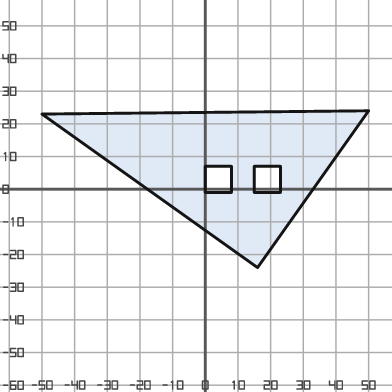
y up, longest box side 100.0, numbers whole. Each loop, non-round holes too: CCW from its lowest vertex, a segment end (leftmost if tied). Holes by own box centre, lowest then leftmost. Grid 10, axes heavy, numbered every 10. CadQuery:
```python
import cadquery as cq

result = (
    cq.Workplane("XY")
    .moveTo(16.0, -24.0)
    .lineTo(50.0, 24.0)
    .lineTo(-50.0, 23.0)
    .close()
    .moveTo(0.0, -1.0)
    .lineTo(8.0, -1.0)
    .lineTo(8.0, 7.0)
    .lineTo(0.0, 7.0)
    .close()
    .moveTo(15.0, -1.0)
    .lineTo(23.0, -1.0)
    .lineTo(23.0, 7.0)
    .lineTo(15.0, 7.0)
    .close()
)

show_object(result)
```